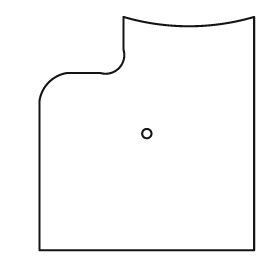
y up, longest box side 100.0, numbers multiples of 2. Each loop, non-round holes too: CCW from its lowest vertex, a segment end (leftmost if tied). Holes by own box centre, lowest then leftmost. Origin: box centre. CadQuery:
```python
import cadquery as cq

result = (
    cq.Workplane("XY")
    .moveTo(-46.0, -50.0)
    .lineTo(46.0, -50.0)
    .lineTo(46.0, 50.0)
    .threePointArc((18.0, 46.0), (-10.0, 50.0))
    .lineTo(-10.0, 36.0)
    .threePointArc((-12.0, 28.0), (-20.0, 26.0))
    .lineTo(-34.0, 26.0)
    .threePointArc((-42.0, 22.0), (-46.0, 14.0))
    .close()
    .moveTo(0.0, 0.0)
    .circle(2.0)
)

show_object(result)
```